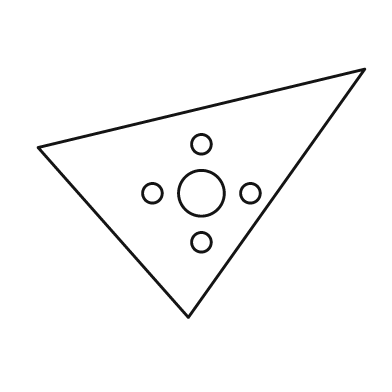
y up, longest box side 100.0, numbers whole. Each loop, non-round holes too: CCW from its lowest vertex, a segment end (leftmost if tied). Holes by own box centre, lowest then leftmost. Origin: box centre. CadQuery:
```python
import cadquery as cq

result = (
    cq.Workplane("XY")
    .moveTo(-4.0, -38.0)
    .lineTo(50.0, 38.0)
    .lineTo(-50.0, 14.0)
    .close()
    .moveTo(0.0, -15.0)
    .circle(3.0)
    .moveTo(-15.0, 0.0)
    .circle(3.0)
    .moveTo(0.0, 0.0)
    .circle(7.0)
    .moveTo(15.0, 0.0)
    .circle(3.0)
    .moveTo(0.0, 15.0)
    .circle(3.0)
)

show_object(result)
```